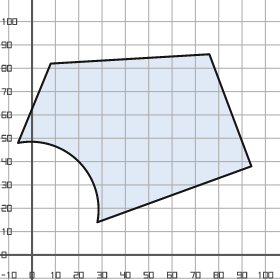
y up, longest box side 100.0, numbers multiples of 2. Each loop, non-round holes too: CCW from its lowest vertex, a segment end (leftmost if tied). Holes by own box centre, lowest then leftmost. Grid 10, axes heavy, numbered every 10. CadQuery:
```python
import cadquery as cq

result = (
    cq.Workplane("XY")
    .moveTo(28.0, 14.0)
    .lineTo(94.0, 38.0)
    .lineTo(76.0, 86.0)
    .lineTo(8.0, 82.0)
    .lineTo(-6.0, 48.0)
    .threePointArc((20.0, 40.0), (28.0, 14.0))
    .close()
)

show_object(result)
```